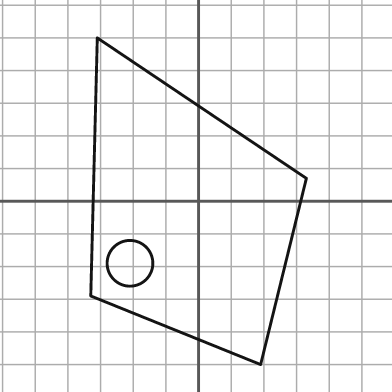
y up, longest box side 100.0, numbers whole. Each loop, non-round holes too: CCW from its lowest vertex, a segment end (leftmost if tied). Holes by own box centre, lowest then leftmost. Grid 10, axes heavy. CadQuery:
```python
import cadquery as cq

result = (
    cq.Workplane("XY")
    .moveTo(19.0, -50.0)
    .lineTo(33.0, 7.0)
    .lineTo(-31.0, 50.0)
    .lineTo(-33.0, -29.0)
    .close()
    .moveTo(-21.0, -19.0)
    .circle(7.0)
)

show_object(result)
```